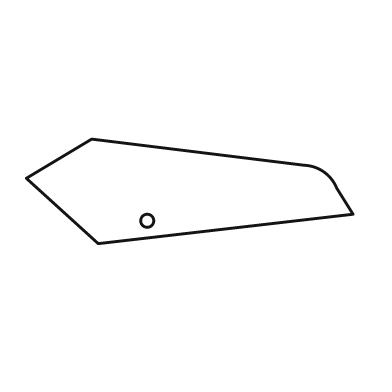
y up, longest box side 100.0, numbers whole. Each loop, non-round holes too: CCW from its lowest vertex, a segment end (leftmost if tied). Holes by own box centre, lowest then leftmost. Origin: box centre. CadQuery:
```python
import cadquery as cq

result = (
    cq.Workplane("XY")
    .moveTo(-28.0, -16.0)
    .lineTo(50.0, -7.0)
    .lineTo(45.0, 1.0)
    .threePointArc((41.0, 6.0), (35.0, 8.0))
    .lineTo(-30.0, 16.0)
    .lineTo(-50.0, 4.0)
    .close()
    .moveTo(-13.0, -9.0)
    .circle(2.0)
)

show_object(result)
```